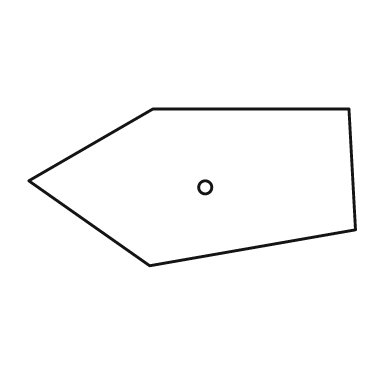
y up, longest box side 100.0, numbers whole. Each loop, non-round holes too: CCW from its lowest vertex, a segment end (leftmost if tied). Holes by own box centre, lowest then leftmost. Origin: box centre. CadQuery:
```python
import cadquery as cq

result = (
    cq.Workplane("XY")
    .moveTo(-13.0, -24.0)
    .lineTo(50.0, -13.0)
    .lineTo(48.0, 24.0)
    .lineTo(-12.0, 24.0)
    .lineTo(-50.0, 2.0)
    .close()
    .moveTo(4.0, 0.0)
    .circle(2.0)
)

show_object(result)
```